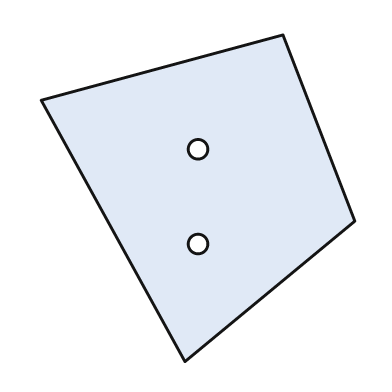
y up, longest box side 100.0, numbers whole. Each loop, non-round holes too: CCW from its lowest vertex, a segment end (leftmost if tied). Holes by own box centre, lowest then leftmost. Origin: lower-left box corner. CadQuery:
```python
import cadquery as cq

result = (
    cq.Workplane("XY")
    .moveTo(44.0, 0.0)
    .lineTo(96.0, 43.0)
    .lineTo(74.0, 100.0)
    .lineTo(0.0, 80.0)
    .close()
    .moveTo(48.0, 36.0)
    .circle(3.0)
    .moveTo(48.0, 65.0)
    .circle(3.0)
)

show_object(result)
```